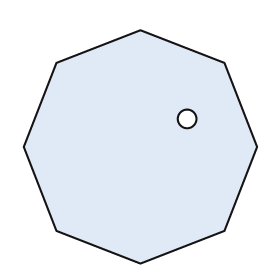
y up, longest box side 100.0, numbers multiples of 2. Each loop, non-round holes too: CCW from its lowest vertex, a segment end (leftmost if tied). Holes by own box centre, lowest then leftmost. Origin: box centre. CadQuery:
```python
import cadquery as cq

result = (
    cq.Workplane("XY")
    .moveTo(0.0, -50.0)
    .lineTo(36.0, -36.0)
    .lineTo(50.0, 0.0)
    .lineTo(36.0, 36.0)
    .lineTo(0.0, 50.0)
    .lineTo(-36.0, 36.0)
    .lineTo(-50.0, 0.0)
    .lineTo(-36.0, -36.0)
    .close()
    .moveTo(20.0, 12.0)
    .circle(4.0)
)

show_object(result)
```